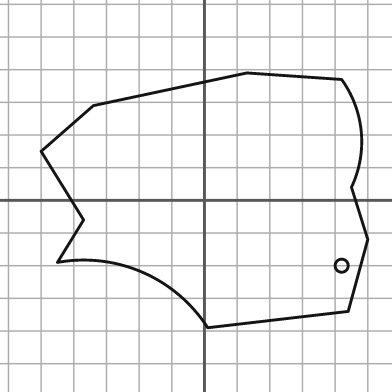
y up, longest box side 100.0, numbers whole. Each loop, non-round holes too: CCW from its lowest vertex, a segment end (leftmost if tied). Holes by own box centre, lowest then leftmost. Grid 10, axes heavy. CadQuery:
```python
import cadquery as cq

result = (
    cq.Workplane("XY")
    .moveTo(1.0, -39.0)
    .lineTo(44.0, -34.0)
    .lineTo(50.0, -12.0)
    .lineTo(45.0, 4.0)
    .threePointArc((48.0, 21.0), (42.0, 37.0))
    .lineTo(13.0, 39.0)
    .lineTo(-34.0, 29.0)
    .lineTo(-50.0, 15.0)
    .lineTo(-37.0, -6.0)
    .lineTo(-45.0, -19.0)
    .threePointArc((-19.0, -22.0), (1.0, -39.0))
    .close()
    .moveTo(42.0, -20.0)
    .circle(2.0)
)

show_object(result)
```